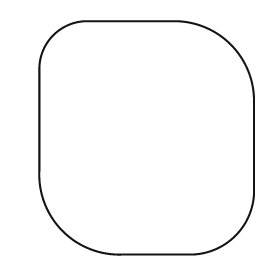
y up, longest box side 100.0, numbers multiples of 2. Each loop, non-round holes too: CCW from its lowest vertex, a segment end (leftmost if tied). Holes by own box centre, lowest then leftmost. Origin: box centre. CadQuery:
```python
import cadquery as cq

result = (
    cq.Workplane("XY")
    .moveTo(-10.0, -50.0)
    .lineTo(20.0, -50.0)
    .threePointArc((38.0, -42.0), (46.0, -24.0))
    .lineTo(46.0, 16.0)
    .threePointArc((36.0, 40.0), (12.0, 50.0))
    .lineTo(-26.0, 50.0)
    .threePointArc((-40.0, 44.0), (-46.0, 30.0))
    .lineTo(-46.0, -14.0)
    .threePointArc((-36.0, -40.0), (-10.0, -50.0))
    .close()
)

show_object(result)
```